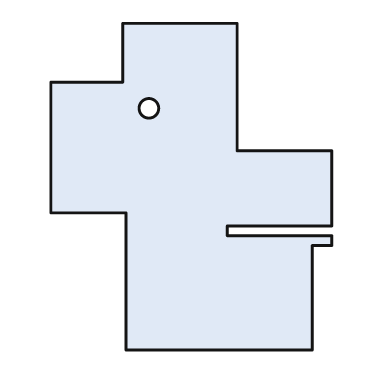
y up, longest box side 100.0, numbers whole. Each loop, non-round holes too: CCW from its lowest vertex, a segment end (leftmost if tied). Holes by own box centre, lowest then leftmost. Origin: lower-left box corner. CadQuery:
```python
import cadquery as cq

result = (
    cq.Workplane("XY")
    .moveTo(23.0, 0.0)
    .lineTo(80.0, 0.0)
    .lineTo(80.0, 32.0)
    .lineTo(86.0, 32.0)
    .lineTo(86.0, 35.0)
    .lineTo(54.0, 35.0)
    .lineTo(54.0, 38.0)
    .lineTo(86.0, 38.0)
    .lineTo(86.0, 61.0)
    .lineTo(57.0, 61.0)
    .lineTo(57.0, 100.0)
    .lineTo(22.0, 100.0)
    .lineTo(22.0, 82.0)
    .lineTo(0.0, 82.0)
    .lineTo(0.0, 42.0)
    .lineTo(23.0, 42.0)
    .close()
    .moveTo(30.0, 74.0)
    .circle(3.0)
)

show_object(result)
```